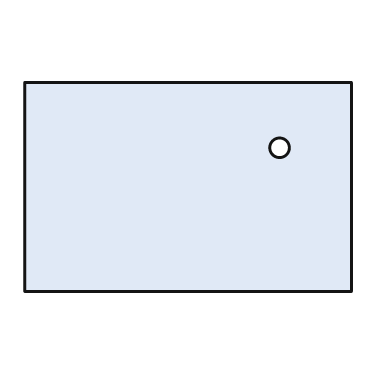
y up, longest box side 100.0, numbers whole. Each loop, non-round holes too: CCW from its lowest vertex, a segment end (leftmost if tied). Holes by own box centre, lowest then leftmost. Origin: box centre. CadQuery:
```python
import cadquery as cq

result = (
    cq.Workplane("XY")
    .moveTo(-50.0, -32.0)
    .lineTo(50.0, -32.0)
    .lineTo(50.0, 32.0)
    .lineTo(-50.0, 32.0)
    .close()
    .moveTo(28.0, 12.0)
    .circle(3.0)
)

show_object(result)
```